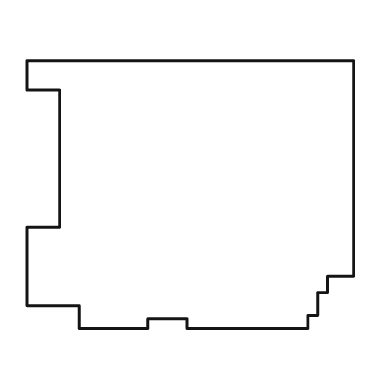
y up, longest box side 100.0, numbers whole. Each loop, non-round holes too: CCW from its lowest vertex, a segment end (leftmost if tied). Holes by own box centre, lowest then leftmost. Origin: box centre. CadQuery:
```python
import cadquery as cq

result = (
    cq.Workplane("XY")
    .moveTo(-34.0, -41.0)
    .lineTo(-13.0, -41.0)
    .lineTo(-13.0, -38.0)
    .lineTo(-1.0, -38.0)
    .lineTo(-1.0, -41.0)
    .lineTo(36.0, -41.0)
    .lineTo(36.0, -37.0)
    .lineTo(39.0, -37.0)
    .lineTo(39.0, -30.0)
    .lineTo(42.0, -30.0)
    .lineTo(42.0, -25.0)
    .lineTo(50.0, -25.0)
    .lineTo(50.0, 41.0)
    .lineTo(-50.0, 41.0)
    .lineTo(-50.0, 32.0)
    .lineTo(-40.0, 32.0)
    .lineTo(-40.0, -10.0)
    .lineTo(-50.0, -10.0)
    .lineTo(-50.0, -34.0)
    .lineTo(-34.0, -34.0)
    .close()
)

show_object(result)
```